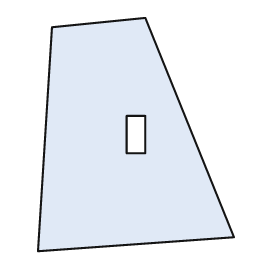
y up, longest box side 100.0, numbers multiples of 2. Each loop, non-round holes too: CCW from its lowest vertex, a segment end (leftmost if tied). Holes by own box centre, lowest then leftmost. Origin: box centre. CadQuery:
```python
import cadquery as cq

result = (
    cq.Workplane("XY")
    .moveTo(-42.0, -50.0)
    .lineTo(42.0, -44.0)
    .lineTo(4.0, 50.0)
    .lineTo(-36.0, 46.0)
    .close()
    .moveTo(-4.0, -8.0)
    .lineTo(4.0, -8.0)
    .lineTo(4.0, 8.0)
    .lineTo(-4.0, 8.0)
    .close()
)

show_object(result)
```